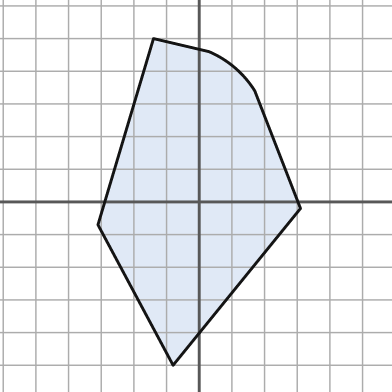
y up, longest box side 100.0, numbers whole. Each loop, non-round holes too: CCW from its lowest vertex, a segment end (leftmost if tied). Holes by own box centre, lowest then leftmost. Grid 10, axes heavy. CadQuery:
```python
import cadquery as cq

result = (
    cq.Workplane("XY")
    .moveTo(-8.0, -50.0)
    .lineTo(31.0, -2.0)
    .lineTo(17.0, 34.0)
    .threePointArc((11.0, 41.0), (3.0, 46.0))
    .lineTo(-14.0, 50.0)
    .lineTo(-31.0, -7.0)
    .close()
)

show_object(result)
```